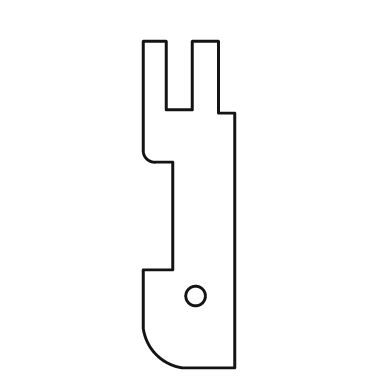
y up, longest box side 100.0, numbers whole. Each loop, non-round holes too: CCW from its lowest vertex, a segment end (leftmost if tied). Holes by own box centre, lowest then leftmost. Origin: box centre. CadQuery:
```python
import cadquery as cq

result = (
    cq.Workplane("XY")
    .moveTo(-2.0, -50.0)
    .lineTo(14.0, -50.0)
    .lineTo(14.0, 28.0)
    .lineTo(9.0, 28.0)
    .lineTo(9.0, 50.0)
    .lineTo(1.0, 50.0)
    .lineTo(1.0, 29.0)
    .lineTo(-7.0, 29.0)
    .lineTo(-7.0, 50.0)
    .lineTo(-14.0, 50.0)
    .lineTo(-14.0, 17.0)
    .threePointArc((-13.0, 14.0), (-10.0, 13.0))
    .lineTo(-5.0, 13.0)
    .lineTo(-5.0, -20.0)
    .lineTo(-14.0, -20.0)
    .lineTo(-14.0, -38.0)
    .threePointArc((-10.0, -46.0), (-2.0, -50.0))
    .close()
    .moveTo(2.0, -28.0)
    .circle(3.0)
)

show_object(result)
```